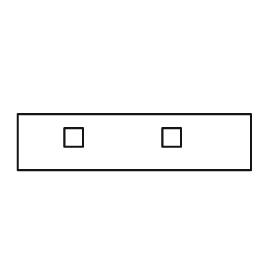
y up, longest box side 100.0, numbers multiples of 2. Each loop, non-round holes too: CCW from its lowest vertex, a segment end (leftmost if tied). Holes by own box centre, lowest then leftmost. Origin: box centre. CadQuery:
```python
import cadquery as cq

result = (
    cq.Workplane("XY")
    .moveTo(-50.0, -12.0)
    .lineTo(50.0, -12.0)
    .lineTo(50.0, 12.0)
    .lineTo(-50.0, 12.0)
    .close()
    .moveTo(-30.0, -2.0)
    .lineTo(-22.0, -2.0)
    .lineTo(-22.0, 6.0)
    .lineTo(-30.0, 6.0)
    .close()
    .moveTo(12.0, -2.0)
    .lineTo(20.0, -2.0)
    .lineTo(20.0, 6.0)
    .lineTo(12.0, 6.0)
    .close()
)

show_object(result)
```